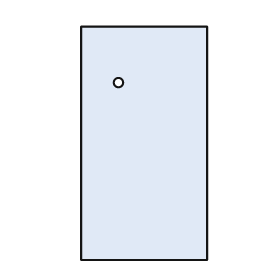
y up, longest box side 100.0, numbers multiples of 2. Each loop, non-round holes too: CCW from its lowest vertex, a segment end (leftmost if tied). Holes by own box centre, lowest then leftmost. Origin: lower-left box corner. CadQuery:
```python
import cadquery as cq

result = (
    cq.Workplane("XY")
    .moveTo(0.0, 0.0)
    .lineTo(54.0, 0.0)
    .lineTo(54.0, 100.0)
    .lineTo(0.0, 100.0)
    .close()
    .moveTo(16.0, 76.0)
    .circle(2.0)
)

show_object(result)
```